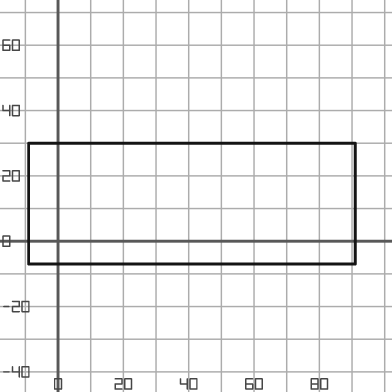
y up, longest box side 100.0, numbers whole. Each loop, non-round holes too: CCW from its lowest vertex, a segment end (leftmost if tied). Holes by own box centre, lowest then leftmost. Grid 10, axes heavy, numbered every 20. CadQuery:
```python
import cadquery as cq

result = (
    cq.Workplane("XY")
    .moveTo(-9.0, -7.0)
    .lineTo(91.0, -7.0)
    .lineTo(91.0, 30.0)
    .lineTo(-9.0, 30.0)
    .close()
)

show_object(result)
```